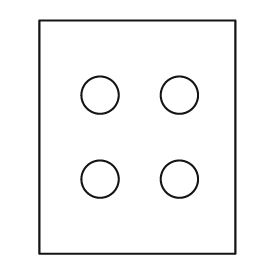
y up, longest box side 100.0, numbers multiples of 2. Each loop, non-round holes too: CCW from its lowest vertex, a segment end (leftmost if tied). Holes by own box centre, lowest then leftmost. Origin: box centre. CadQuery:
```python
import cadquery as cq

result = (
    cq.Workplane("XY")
    .moveTo(-42.0, -50.0)
    .lineTo(42.0, -50.0)
    .lineTo(42.0, 50.0)
    .lineTo(-42.0, 50.0)
    .close()
    .moveTo(-16.0, -18.0)
    .circle(8.0)
    .moveTo(18.0, -18.0)
    .circle(8.0)
    .moveTo(-16.0, 18.0)
    .circle(8.0)
    .moveTo(18.0, 18.0)
    .circle(8.0)
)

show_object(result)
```